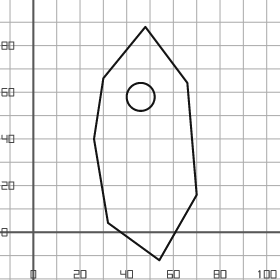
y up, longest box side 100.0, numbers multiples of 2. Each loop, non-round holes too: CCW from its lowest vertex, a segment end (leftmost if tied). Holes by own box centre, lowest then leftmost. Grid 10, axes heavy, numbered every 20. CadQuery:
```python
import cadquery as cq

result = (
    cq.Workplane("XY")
    .moveTo(54.0, -12.0)
    .lineTo(70.0, 16.0)
    .lineTo(66.0, 64.0)
    .lineTo(48.0, 88.0)
    .lineTo(30.0, 66.0)
    .lineTo(26.0, 40.0)
    .lineTo(32.0, 4.0)
    .close()
    .moveTo(46.0, 58.0)
    .circle(6.0)
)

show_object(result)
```